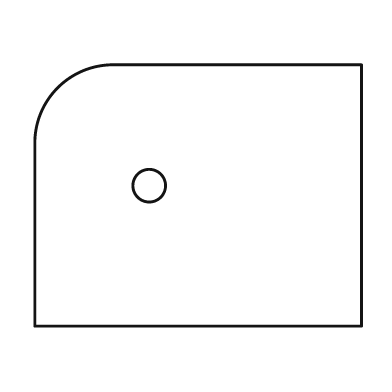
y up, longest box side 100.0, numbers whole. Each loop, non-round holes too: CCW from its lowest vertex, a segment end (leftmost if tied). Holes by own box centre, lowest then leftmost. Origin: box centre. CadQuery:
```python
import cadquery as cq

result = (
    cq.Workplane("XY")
    .moveTo(-50.0, -40.0)
    .lineTo(50.0, -40.0)
    .lineTo(50.0, 40.0)
    .lineTo(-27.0, 40.0)
    .threePointArc((-43.0, 33.0), (-50.0, 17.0))
    .close()
    .moveTo(-15.0, 3.0)
    .circle(5.0)
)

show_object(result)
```